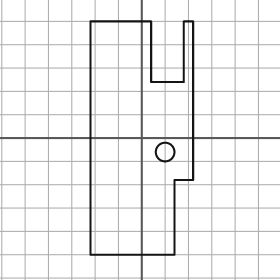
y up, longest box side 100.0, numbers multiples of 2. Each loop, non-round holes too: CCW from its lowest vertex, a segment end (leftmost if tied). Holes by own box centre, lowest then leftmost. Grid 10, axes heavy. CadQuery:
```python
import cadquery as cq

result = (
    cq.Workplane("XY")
    .moveTo(-22.0, -50.0)
    .lineTo(14.0, -50.0)
    .lineTo(14.0, -18.0)
    .lineTo(22.0, -18.0)
    .lineTo(22.0, 50.0)
    .lineTo(18.0, 50.0)
    .lineTo(18.0, 24.0)
    .lineTo(4.0, 24.0)
    .lineTo(4.0, 50.0)
    .lineTo(-22.0, 50.0)
    .close()
    .moveTo(10.0, -6.0)
    .circle(4.0)
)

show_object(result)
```